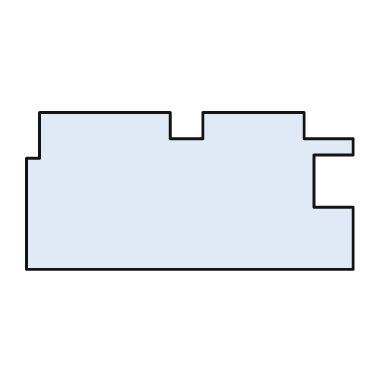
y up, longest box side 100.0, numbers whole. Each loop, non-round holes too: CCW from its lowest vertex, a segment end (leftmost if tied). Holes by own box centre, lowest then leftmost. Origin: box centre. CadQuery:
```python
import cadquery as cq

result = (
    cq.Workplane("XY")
    .moveTo(-50.0, -24.0)
    .lineTo(50.0, -24.0)
    .lineTo(50.0, -5.0)
    .lineTo(38.0, -5.0)
    .lineTo(38.0, 11.0)
    .lineTo(50.0, 11.0)
    .lineTo(50.0, 16.0)
    .lineTo(35.0, 16.0)
    .lineTo(35.0, 24.0)
    .lineTo(4.0, 24.0)
    .lineTo(4.0, 16.0)
    .lineTo(-6.0, 16.0)
    .lineTo(-6.0, 24.0)
    .lineTo(-46.0, 24.0)
    .lineTo(-46.0, 10.0)
    .lineTo(-50.0, 10.0)
    .close()
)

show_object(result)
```